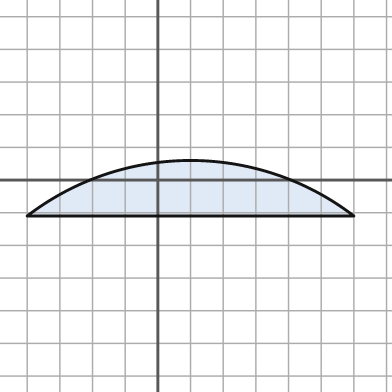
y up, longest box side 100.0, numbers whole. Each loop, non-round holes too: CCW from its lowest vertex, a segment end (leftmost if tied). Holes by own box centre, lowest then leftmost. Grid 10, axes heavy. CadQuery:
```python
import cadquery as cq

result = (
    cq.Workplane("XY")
    .moveTo(-40.0, -11.0)
    .lineTo(60.0, -11.0)
    .threePointArc((10.0, 6.0), (-40.0, -11.0))
    .close()
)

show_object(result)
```